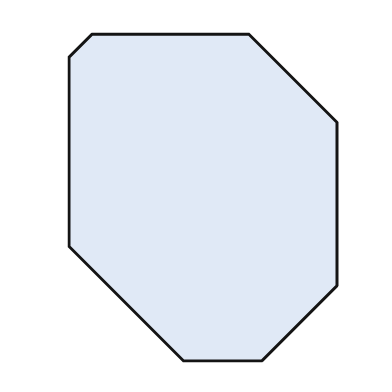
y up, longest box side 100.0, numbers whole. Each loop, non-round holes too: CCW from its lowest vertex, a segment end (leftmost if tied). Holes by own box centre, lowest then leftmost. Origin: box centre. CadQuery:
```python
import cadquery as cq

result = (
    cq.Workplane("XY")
    .moveTo(-6.0, -50.0)
    .lineTo(18.0, -50.0)
    .lineTo(41.0, -27.0)
    .lineTo(41.0, 23.0)
    .lineTo(14.0, 50.0)
    .lineTo(-34.0, 50.0)
    .lineTo(-41.0, 43.0)
    .lineTo(-41.0, -15.0)
    .close()
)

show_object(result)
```